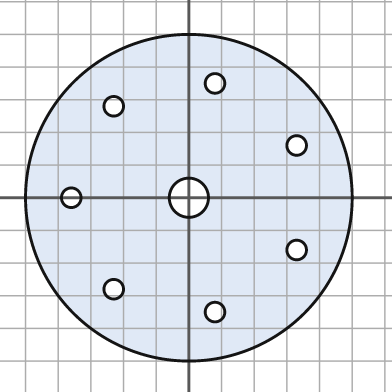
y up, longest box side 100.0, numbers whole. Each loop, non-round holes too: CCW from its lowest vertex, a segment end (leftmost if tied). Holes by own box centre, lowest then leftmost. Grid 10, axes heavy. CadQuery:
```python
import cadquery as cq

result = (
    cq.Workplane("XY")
    .moveTo(0.0, 0.0)
    .circle(50.0)
    .moveTo(8.0, -35.0)
    .circle(3.0)
    .moveTo(-23.0, -28.0)
    .circle(3.0)
    .moveTo(33.0, -16.0)
    .circle(3.0)
    .moveTo(-36.0, 0.0)
    .circle(3.0)
    .moveTo(0.0, 0.0)
    .circle(6.0)
    .moveTo(33.0, 16.0)
    .circle(3.0)
    .moveTo(-23.0, 28.0)
    .circle(3.0)
    .moveTo(8.0, 35.0)
    .circle(3.0)
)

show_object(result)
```